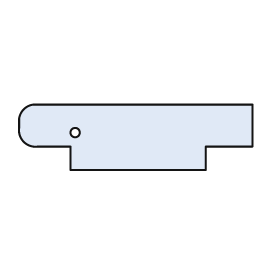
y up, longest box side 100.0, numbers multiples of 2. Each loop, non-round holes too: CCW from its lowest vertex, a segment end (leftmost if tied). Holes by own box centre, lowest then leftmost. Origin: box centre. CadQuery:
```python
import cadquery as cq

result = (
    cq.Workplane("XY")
    .moveTo(-28.0, -14.0)
    .lineTo(30.0, -14.0)
    .lineTo(30.0, -4.0)
    .lineTo(50.0, -4.0)
    .lineTo(50.0, 14.0)
    .lineTo(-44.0, 14.0)
    .threePointArc((-48.0, 12.0), (-50.0, 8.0))
    .lineTo(-50.0, 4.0)
    .threePointArc((-48.0, -2.0), (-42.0, -4.0))
    .lineTo(-28.0, -4.0)
    .close()
    .moveTo(-26.0, 2.0)
    .circle(2.0)
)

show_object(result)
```